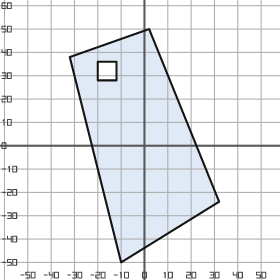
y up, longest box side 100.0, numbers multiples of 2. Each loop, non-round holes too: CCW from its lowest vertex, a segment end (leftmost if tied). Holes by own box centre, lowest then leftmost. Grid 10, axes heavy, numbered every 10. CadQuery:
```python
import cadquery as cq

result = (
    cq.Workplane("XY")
    .moveTo(-10.0, -50.0)
    .lineTo(32.0, -24.0)
    .lineTo(2.0, 50.0)
    .lineTo(-32.0, 38.0)
    .close()
    .moveTo(-20.0, 28.0)
    .lineTo(-12.0, 28.0)
    .lineTo(-12.0, 36.0)
    .lineTo(-20.0, 36.0)
    .close()
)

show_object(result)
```